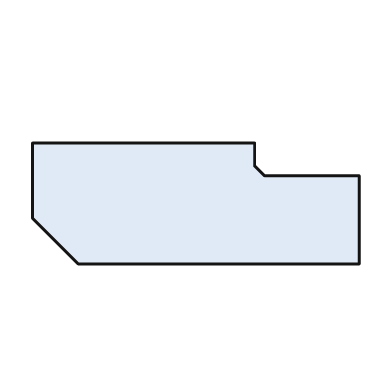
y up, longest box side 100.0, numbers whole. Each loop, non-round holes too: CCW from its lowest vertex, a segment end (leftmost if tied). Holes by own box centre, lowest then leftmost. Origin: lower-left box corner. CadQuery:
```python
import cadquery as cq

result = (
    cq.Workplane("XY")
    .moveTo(14.0, 0.0)
    .lineTo(100.0, 0.0)
    .lineTo(100.0, 27.0)
    .lineTo(71.0, 27.0)
    .lineTo(68.0, 30.0)
    .lineTo(68.0, 37.0)
    .lineTo(0.0, 37.0)
    .lineTo(0.0, 14.0)
    .close()
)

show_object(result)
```